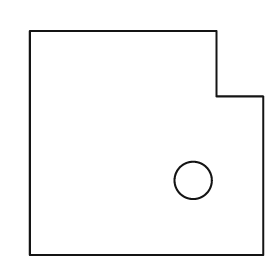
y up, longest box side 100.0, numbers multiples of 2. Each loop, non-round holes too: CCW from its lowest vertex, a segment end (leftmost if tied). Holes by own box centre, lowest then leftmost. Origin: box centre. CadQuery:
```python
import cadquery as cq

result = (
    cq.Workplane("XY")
    .moveTo(-50.0, -48.0)
    .lineTo(50.0, -48.0)
    .lineTo(50.0, 20.0)
    .lineTo(30.0, 20.0)
    .lineTo(30.0, 48.0)
    .lineTo(-50.0, 48.0)
    .close()
    .moveTo(20.0, -16.0)
    .circle(8.0)
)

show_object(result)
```